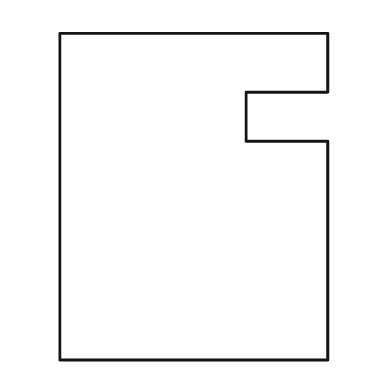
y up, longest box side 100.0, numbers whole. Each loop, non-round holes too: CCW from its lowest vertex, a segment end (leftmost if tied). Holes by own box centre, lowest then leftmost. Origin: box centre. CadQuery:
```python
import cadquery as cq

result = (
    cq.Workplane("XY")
    .moveTo(-41.0, -50.0)
    .lineTo(41.0, -50.0)
    .lineTo(41.0, 17.0)
    .lineTo(16.0, 17.0)
    .lineTo(16.0, 32.0)
    .lineTo(41.0, 32.0)
    .lineTo(41.0, 50.0)
    .lineTo(-41.0, 50.0)
    .close()
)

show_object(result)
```